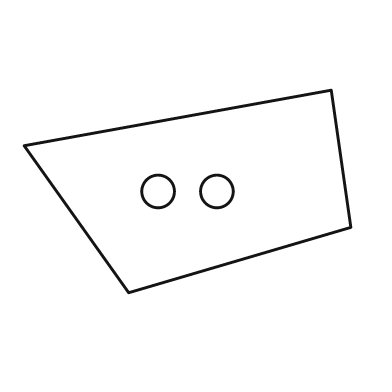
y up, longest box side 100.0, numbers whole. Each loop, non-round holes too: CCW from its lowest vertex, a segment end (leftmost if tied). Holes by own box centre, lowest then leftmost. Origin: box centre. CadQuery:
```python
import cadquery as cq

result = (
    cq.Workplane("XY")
    .moveTo(-18.0, -31.0)
    .lineTo(50.0, -11.0)
    .lineTo(44.0, 31.0)
    .lineTo(-50.0, 14.0)
    .close()
    .moveTo(-9.0, 0.0)
    .circle(5.0)
    .moveTo(9.0, 0.0)
    .circle(5.0)
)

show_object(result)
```